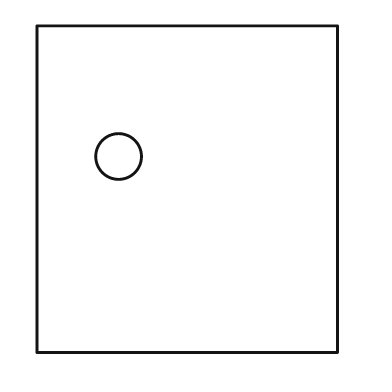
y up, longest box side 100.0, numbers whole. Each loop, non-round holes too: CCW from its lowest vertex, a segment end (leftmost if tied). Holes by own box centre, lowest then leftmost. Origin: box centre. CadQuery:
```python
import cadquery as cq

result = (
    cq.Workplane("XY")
    .moveTo(-46.0, -50.0)
    .lineTo(46.0, -50.0)
    .lineTo(46.0, 50.0)
    .lineTo(-46.0, 50.0)
    .close()
    .moveTo(-21.0, 10.0)
    .circle(7.0)
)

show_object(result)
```